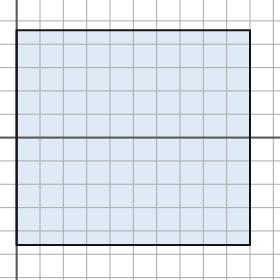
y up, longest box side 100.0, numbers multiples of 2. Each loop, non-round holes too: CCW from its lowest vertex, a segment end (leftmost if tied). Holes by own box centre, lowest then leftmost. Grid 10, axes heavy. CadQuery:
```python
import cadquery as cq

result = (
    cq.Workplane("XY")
    .moveTo(0.0, -46.0)
    .lineTo(100.0, -46.0)
    .lineTo(100.0, 46.0)
    .lineTo(0.0, 46.0)
    .close()
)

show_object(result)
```